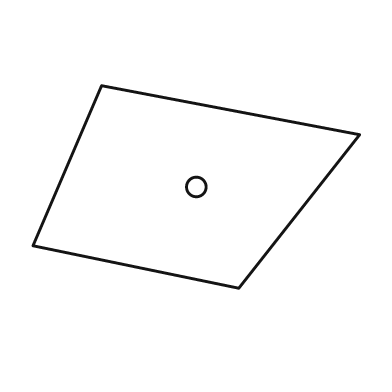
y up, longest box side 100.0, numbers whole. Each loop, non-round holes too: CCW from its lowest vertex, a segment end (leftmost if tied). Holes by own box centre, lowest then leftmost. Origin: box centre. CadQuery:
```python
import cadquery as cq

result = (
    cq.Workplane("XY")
    .moveTo(13.0, -31.0)
    .lineTo(50.0, 16.0)
    .lineTo(-29.0, 31.0)
    .lineTo(-50.0, -18.0)
    .close()
    .moveTo(0.0, 0.0)
    .circle(3.0)
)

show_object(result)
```